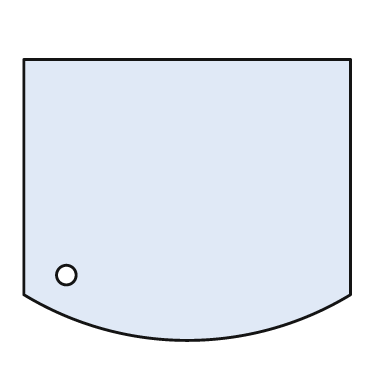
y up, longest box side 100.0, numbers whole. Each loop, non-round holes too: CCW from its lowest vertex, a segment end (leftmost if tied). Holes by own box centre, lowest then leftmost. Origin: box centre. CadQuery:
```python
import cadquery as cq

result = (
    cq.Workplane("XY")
    .moveTo(-50.0, -29.0)
    .threePointArc((0.0, -43.0), (50.0, -29.0))
    .lineTo(50.0, 43.0)
    .lineTo(-50.0, 43.0)
    .close()
    .moveTo(-37.0, -23.0)
    .circle(3.0)
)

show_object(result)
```